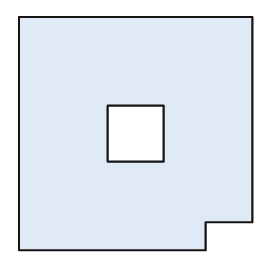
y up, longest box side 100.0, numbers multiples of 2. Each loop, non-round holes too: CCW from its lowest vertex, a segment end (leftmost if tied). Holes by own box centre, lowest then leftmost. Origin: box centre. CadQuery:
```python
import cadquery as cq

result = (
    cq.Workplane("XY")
    .moveTo(-50.0, -50.0)
    .lineTo(30.0, -50.0)
    .lineTo(30.0, -38.0)
    .lineTo(50.0, -38.0)
    .lineTo(50.0, 50.0)
    .lineTo(-50.0, 50.0)
    .close()
    .moveTo(-12.0, -12.0)
    .lineTo(12.0, -12.0)
    .lineTo(12.0, 12.0)
    .lineTo(-12.0, 12.0)
    .close()
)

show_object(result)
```